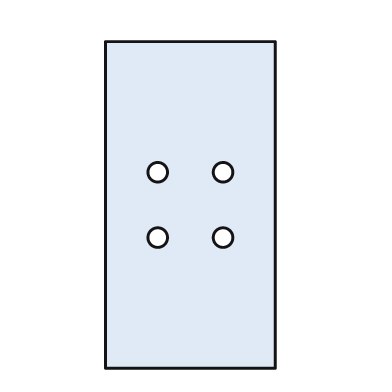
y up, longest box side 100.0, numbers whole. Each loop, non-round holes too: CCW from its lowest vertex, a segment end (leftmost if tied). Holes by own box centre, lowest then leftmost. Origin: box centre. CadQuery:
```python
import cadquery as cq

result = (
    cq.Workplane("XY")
    .moveTo(-26.0, -50.0)
    .lineTo(26.0, -50.0)
    .lineTo(26.0, 50.0)
    .lineTo(-26.0, 50.0)
    .close()
    .moveTo(-10.0, -10.0)
    .circle(3.0)
    .moveTo(10.0, -10.0)
    .circle(3.0)
    .moveTo(-10.0, 10.0)
    .circle(3.0)
    .moveTo(10.0, 10.0)
    .circle(3.0)
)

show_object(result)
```